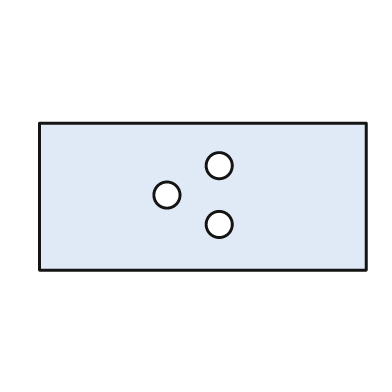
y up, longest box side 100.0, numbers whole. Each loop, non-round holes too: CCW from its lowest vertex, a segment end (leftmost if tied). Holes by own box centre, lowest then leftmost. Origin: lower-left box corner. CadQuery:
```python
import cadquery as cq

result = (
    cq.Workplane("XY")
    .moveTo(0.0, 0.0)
    .lineTo(100.0, 0.0)
    .lineTo(100.0, 45.0)
    .lineTo(0.0, 45.0)
    .close()
    .moveTo(55.0, 14.0)
    .circle(4.0)
    .moveTo(39.0, 23.0)
    .circle(4.0)
    .moveTo(55.0, 32.0)
    .circle(4.0)
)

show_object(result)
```